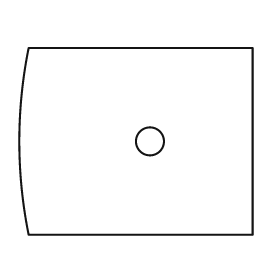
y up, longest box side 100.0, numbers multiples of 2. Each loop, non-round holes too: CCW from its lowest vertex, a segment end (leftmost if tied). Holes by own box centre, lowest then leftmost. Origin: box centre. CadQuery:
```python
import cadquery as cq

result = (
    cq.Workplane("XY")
    .moveTo(-46.0, -40.0)
    .lineTo(50.0, -40.0)
    .lineTo(50.0, 40.0)
    .lineTo(-46.0, 40.0)
    .threePointArc((-50.0, 0.0), (-46.0, -40.0))
    .close()
    .moveTo(6.0, 0.0)
    .circle(6.0)
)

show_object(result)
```